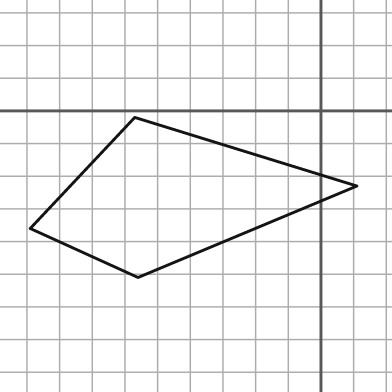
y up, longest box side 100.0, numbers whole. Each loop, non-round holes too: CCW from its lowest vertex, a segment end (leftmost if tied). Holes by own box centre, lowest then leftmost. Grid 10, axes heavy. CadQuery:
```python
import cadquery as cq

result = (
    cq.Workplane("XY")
    .moveTo(-56.0, -51.0)
    .lineTo(11.0, -23.0)
    .lineTo(-57.0, -2.0)
    .lineTo(-89.0, -36.0)
    .close()
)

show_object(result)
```